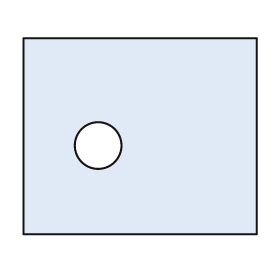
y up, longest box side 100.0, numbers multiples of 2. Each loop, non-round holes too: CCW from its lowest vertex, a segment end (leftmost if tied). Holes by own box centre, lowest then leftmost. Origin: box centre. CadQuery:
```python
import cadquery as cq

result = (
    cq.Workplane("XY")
    .moveTo(-50.0, -42.0)
    .lineTo(50.0, -42.0)
    .lineTo(50.0, 42.0)
    .lineTo(-50.0, 42.0)
    .close()
    .moveTo(-18.0, -4.0)
    .circle(10.0)
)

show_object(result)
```